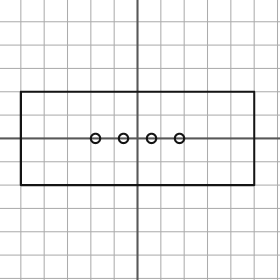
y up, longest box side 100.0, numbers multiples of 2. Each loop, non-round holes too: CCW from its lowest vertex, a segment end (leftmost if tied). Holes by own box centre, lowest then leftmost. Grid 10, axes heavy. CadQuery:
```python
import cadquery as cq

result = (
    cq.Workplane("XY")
    .moveTo(-50.0, -20.0)
    .lineTo(50.0, -20.0)
    .lineTo(50.0, 20.0)
    .lineTo(-50.0, 20.0)
    .close()
    .moveTo(-18.0, 0.0)
    .circle(2.0)
    .moveTo(-6.0, 0.0)
    .circle(2.0)
    .moveTo(6.0, 0.0)
    .circle(2.0)
    .moveTo(18.0, 0.0)
    .circle(2.0)
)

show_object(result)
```